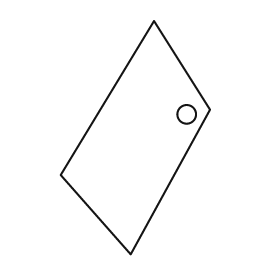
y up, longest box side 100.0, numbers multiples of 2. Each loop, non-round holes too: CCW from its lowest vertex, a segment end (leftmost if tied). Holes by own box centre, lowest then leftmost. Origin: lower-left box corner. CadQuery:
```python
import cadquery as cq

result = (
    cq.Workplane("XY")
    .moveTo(30.0, 0.0)
    .lineTo(64.0, 62.0)
    .lineTo(40.0, 100.0)
    .lineTo(0.0, 34.0)
    .close()
    .moveTo(54.0, 60.0)
    .circle(4.0)
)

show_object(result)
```